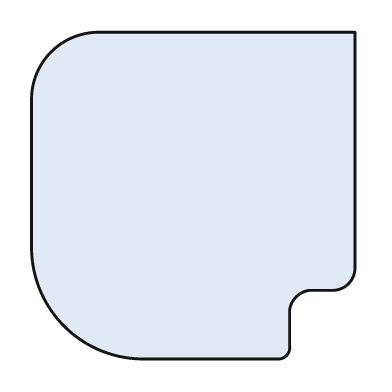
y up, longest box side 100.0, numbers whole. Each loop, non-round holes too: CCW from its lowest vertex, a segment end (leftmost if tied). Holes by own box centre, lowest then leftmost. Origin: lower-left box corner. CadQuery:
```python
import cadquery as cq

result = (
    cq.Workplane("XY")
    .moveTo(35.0, 0.0)
    .lineTo(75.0, 0.0)
    .threePointArc((78.0, 1.0), (79.0, 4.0))
    .lineTo(79.0, 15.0)
    .threePointArc((81.0, 19.0), (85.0, 21.0))
    .lineTo(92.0, 21.0)
    .threePointArc((97.0, 23.0), (99.0, 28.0))
    .lineTo(99.0, 100.0)
    .lineTo(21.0, 100.0)
    .threePointArc((6.0, 94.0), (0.0, 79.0))
    .lineTo(0.0, 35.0)
    .threePointArc((10.0, 10.0), (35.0, 0.0))
    .close()
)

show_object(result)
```